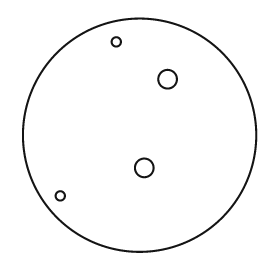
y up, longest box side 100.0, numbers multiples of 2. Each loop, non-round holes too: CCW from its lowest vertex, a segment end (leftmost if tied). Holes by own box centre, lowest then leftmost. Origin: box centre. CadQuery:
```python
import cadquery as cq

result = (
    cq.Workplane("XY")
    .moveTo(0.0, 0.0)
    .circle(50.0)
    .moveTo(-34.0, -26.0)
    .circle(2.0)
    .moveTo(2.0, -14.0)
    .circle(4.0)
    .moveTo(12.0, 24.0)
    .circle(4.0)
    .moveTo(-10.0, 40.0)
    .circle(2.0)
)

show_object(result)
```